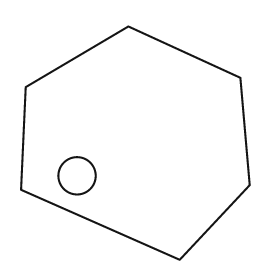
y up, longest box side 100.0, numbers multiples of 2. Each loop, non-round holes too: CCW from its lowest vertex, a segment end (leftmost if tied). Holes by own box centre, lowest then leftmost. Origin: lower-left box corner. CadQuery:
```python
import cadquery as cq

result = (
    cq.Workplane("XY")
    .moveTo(68.0, 0.0)
    .lineTo(98.0, 32.0)
    .lineTo(94.0, 78.0)
    .lineTo(46.0, 100.0)
    .lineTo(2.0, 74.0)
    .lineTo(0.0, 30.0)
    .close()
    .moveTo(24.0, 36.0)
    .circle(8.0)
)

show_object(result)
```